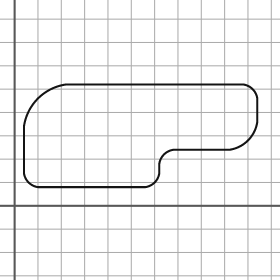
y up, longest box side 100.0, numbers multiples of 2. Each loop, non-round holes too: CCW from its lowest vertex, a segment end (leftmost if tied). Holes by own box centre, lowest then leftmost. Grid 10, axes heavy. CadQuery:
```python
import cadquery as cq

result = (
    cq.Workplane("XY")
    .moveTo(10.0, 8.0)
    .lineTo(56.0, 8.0)
    .threePointArc((60.0, 10.0), (62.0, 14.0))
    .lineTo(62.0, 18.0)
    .threePointArc((64.0, 22.0), (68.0, 24.0))
    .lineTo(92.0, 24.0)
    .threePointArc((100.0, 28.0), (104.0, 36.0))
    .lineTo(104.0, 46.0)
    .threePointArc((102.0, 50.0), (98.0, 52.0))
    .lineTo(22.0, 52.0)
    .threePointArc((10.0, 46.0), (4.0, 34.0))
    .lineTo(4.0, 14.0)
    .threePointArc((6.0, 10.0), (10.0, 8.0))
    .close()
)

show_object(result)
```